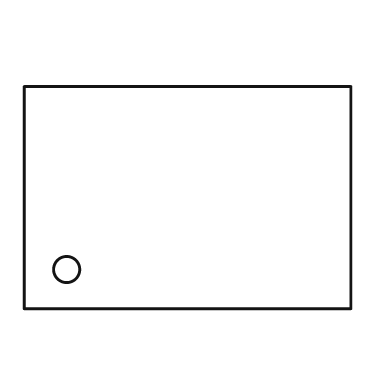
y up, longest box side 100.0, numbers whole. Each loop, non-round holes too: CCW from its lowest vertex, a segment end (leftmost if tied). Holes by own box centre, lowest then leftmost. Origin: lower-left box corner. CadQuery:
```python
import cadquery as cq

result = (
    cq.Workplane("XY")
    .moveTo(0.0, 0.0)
    .lineTo(100.0, 0.0)
    .lineTo(100.0, 68.0)
    .lineTo(0.0, 68.0)
    .close()
    .moveTo(13.0, 12.0)
    .circle(4.0)
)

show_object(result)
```